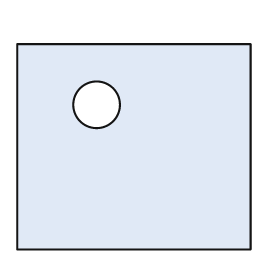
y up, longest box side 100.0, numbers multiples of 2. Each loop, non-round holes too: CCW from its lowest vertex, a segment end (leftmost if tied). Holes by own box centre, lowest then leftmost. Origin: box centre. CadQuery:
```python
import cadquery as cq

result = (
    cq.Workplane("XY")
    .moveTo(-50.0, -44.0)
    .lineTo(50.0, -44.0)
    .lineTo(50.0, 44.0)
    .lineTo(-50.0, 44.0)
    .close()
    .moveTo(-16.0, 18.0)
    .circle(10.0)
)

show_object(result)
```